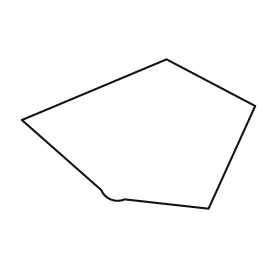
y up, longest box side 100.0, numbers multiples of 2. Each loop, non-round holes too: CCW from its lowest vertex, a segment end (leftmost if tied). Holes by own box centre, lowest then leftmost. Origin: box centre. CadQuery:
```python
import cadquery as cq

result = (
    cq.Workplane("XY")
    .moveTo(30.0, -32.0)
    .lineTo(50.0, 12.0)
    .lineTo(12.0, 32.0)
    .lineTo(-50.0, 6.0)
    .lineTo(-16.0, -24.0)
    .threePointArc((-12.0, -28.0), (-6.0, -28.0))
    .close()
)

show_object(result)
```